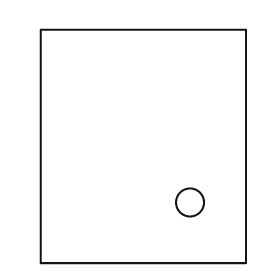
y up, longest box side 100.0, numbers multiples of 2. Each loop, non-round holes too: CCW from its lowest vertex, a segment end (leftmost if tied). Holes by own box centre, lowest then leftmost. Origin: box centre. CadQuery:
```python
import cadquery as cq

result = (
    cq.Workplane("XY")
    .moveTo(-44.0, -50.0)
    .lineTo(44.0, -50.0)
    .lineTo(44.0, 50.0)
    .lineTo(-44.0, 50.0)
    .close()
    .moveTo(20.0, -24.0)
    .circle(6.0)
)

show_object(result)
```